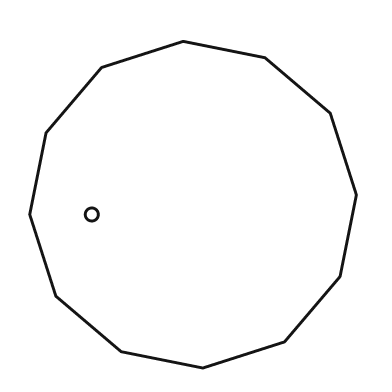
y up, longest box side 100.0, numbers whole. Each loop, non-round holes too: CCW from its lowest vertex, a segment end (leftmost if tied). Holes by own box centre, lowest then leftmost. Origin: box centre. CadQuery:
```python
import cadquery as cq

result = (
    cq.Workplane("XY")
    .moveTo(3.0, -50.0)
    .lineTo(28.0, -42.0)
    .lineTo(45.0, -22.0)
    .lineTo(50.0, 3.0)
    .lineTo(42.0, 28.0)
    .lineTo(22.0, 45.0)
    .lineTo(-3.0, 50.0)
    .lineTo(-28.0, 42.0)
    .lineTo(-45.0, 22.0)
    .lineTo(-50.0, -3.0)
    .lineTo(-42.0, -28.0)
    .lineTo(-22.0, -45.0)
    .close()
    .moveTo(-31.0, -3.0)
    .circle(2.0)
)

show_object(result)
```